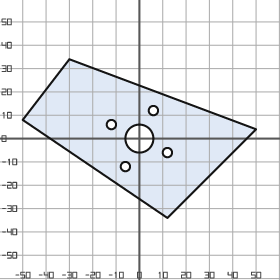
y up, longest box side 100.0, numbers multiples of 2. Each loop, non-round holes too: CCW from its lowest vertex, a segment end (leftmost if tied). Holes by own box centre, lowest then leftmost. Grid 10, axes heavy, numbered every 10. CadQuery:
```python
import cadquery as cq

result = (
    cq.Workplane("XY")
    .moveTo(12.0, -34.0)
    .lineTo(50.0, 4.0)
    .lineTo(-30.0, 34.0)
    .lineTo(-50.0, 8.0)
    .close()
    .moveTo(-6.0, -12.0)
    .circle(2.0)
    .moveTo(12.0, -6.0)
    .circle(2.0)
    .moveTo(0.0, 0.0)
    .circle(6.0)
    .moveTo(-12.0, 6.0)
    .circle(2.0)
    .moveTo(6.0, 12.0)
    .circle(2.0)
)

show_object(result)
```